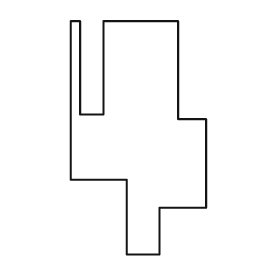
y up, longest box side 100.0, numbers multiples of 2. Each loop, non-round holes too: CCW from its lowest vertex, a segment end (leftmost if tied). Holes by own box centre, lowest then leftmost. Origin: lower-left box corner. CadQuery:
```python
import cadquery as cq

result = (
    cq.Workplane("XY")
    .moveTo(24.0, 0.0)
    .lineTo(38.0, 0.0)
    .lineTo(38.0, 20.0)
    .lineTo(58.0, 20.0)
    .lineTo(58.0, 58.0)
    .lineTo(46.0, 58.0)
    .lineTo(46.0, 100.0)
    .lineTo(14.0, 100.0)
    .lineTo(14.0, 60.0)
    .lineTo(4.0, 60.0)
    .lineTo(4.0, 100.0)
    .lineTo(0.0, 100.0)
    .lineTo(0.0, 32.0)
    .lineTo(24.0, 32.0)
    .close()
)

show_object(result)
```